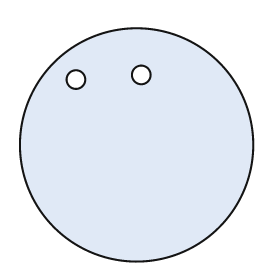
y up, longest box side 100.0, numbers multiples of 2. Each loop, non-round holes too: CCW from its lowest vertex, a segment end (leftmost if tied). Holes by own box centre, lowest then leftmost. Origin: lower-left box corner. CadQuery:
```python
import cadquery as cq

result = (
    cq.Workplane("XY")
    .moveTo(50.0, 50.0)
    .circle(50.0)
    .moveTo(24.0, 78.0)
    .circle(4.0)
    .moveTo(52.0, 80.0)
    .circle(4.0)
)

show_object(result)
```